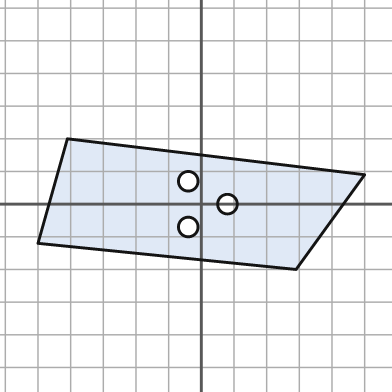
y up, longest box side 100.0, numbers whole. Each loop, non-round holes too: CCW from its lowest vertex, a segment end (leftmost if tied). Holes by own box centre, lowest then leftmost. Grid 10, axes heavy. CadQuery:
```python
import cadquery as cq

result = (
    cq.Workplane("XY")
    .moveTo(29.0, -20.0)
    .lineTo(50.0, 9.0)
    .lineTo(-41.0, 20.0)
    .lineTo(-50.0, -12.0)
    .close()
    .moveTo(-4.0, -7.0)
    .circle(3.0)
    .moveTo(8.0, 0.0)
    .circle(3.0)
    .moveTo(-4.0, 7.0)
    .circle(3.0)
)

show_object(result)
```